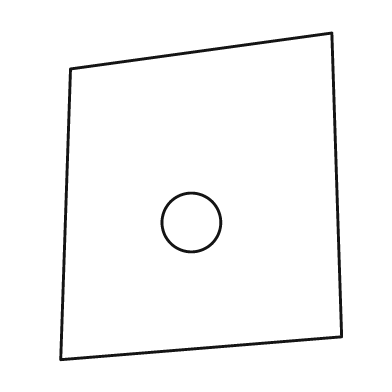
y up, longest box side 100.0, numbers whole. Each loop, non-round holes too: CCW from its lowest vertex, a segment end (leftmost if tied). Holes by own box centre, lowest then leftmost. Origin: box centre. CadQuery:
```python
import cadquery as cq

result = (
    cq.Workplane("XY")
    .moveTo(-43.0, -50.0)
    .lineTo(43.0, -43.0)
    .lineTo(40.0, 50.0)
    .lineTo(-40.0, 39.0)
    .close()
    .moveTo(-3.0, -8.0)
    .circle(9.0)
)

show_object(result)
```